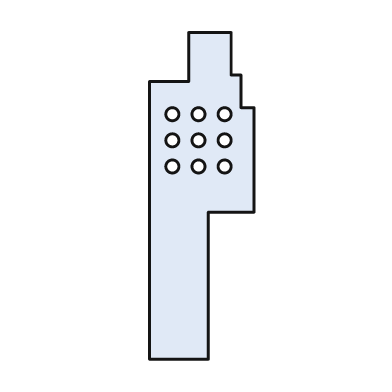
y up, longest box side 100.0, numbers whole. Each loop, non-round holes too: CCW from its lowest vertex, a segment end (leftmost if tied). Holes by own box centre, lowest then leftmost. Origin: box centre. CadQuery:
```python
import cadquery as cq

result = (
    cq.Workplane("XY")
    .moveTo(-16.0, -50.0)
    .lineTo(2.0, -50.0)
    .lineTo(2.0, -5.0)
    .lineTo(16.0, -5.0)
    .lineTo(16.0, 27.0)
    .lineTo(12.0, 27.0)
    .lineTo(12.0, 37.0)
    .lineTo(9.0, 37.0)
    .lineTo(9.0, 50.0)
    .lineTo(-4.0, 50.0)
    .lineTo(-4.0, 35.0)
    .lineTo(-16.0, 35.0)
    .close()
    .moveTo(-9.0, 9.0)
    .circle(2.0)
    .moveTo(-1.0, 9.0)
    .circle(2.0)
    .moveTo(7.0, 9.0)
    .circle(2.0)
    .moveTo(-9.0, 17.0)
    .circle(2.0)
    .moveTo(-1.0, 17.0)
    .circle(2.0)
    .moveTo(7.0, 17.0)
    .circle(2.0)
    .moveTo(-9.0, 25.0)
    .circle(2.0)
    .moveTo(-1.0, 25.0)
    .circle(2.0)
    .moveTo(7.0, 25.0)
    .circle(2.0)
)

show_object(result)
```